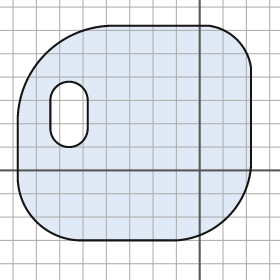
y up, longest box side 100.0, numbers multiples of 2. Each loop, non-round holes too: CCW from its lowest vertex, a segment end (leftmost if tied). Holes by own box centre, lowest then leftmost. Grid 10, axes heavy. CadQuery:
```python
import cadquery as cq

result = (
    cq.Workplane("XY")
    .moveTo(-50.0, -30.0)
    .lineTo(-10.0, -30.0)
    .threePointArc((12.0, -20.0), (22.0, 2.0))
    .lineTo(22.0, 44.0)
    .threePointArc((16.0, 56.0), (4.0, 62.0))
    .lineTo(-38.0, 62.0)
    .threePointArc((-66.0, 50.0), (-78.0, 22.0))
    .lineTo(-78.0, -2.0)
    .threePointArc((-70.0, -22.0), (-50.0, -30.0))
    .close()
    .moveTo(-64.0, 18.0)
    .threePointArc((-56.0, 10.0), (-48.0, 18.0))
    .lineTo(-48.0, 30.0)
    .threePointArc((-56.0, 38.0), (-64.0, 30.0))
    .close()
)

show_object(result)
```